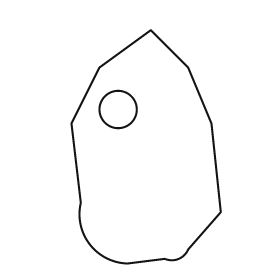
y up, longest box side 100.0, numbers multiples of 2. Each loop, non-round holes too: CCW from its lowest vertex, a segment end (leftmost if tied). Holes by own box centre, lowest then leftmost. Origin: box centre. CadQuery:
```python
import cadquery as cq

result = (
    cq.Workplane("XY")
    .moveTo(-8.0, -50.0)
    .lineTo(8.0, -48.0)
    .threePointArc((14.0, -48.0), (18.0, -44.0))
    .lineTo(32.0, -28.0)
    .lineTo(28.0, 10.0)
    .lineTo(18.0, 34.0)
    .lineTo(2.0, 50.0)
    .lineTo(-20.0, 34.0)
    .lineTo(-32.0, 10.0)
    .lineTo(-28.0, -24.0)
    .threePointArc((-24.0, -42.0), (-8.0, -50.0))
    .close()
    .moveTo(-12.0, 16.0)
    .circle(8.0)
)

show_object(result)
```